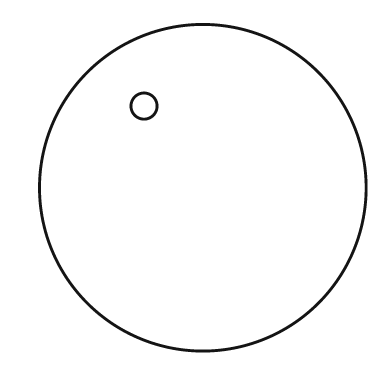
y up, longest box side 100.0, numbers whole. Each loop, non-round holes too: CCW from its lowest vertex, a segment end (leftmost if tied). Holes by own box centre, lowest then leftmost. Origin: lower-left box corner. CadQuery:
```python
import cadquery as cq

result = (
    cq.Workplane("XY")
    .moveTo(50.0, 50.0)
    .circle(50.0)
    .moveTo(32.0, 75.0)
    .circle(4.0)
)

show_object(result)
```